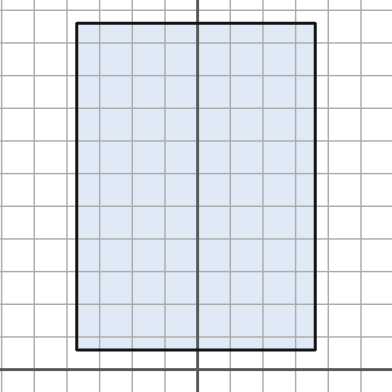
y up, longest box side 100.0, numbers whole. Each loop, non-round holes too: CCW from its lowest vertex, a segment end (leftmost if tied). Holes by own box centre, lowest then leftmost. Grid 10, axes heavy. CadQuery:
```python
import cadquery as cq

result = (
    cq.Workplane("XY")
    .moveTo(-37.0, 6.0)
    .lineTo(36.0, 6.0)
    .lineTo(36.0, 106.0)
    .lineTo(-37.0, 106.0)
    .close()
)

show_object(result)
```